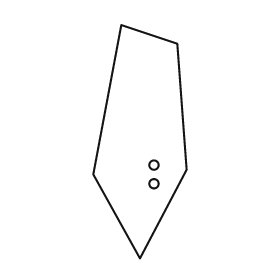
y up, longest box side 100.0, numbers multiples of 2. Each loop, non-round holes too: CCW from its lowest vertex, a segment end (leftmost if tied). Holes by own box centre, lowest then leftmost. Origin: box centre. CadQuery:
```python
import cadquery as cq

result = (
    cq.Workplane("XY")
    .moveTo(0.0, -50.0)
    .lineTo(20.0, -12.0)
    .lineTo(16.0, 42.0)
    .lineTo(-8.0, 50.0)
    .lineTo(-20.0, -14.0)
    .close()
    .moveTo(6.0, -18.0)
    .circle(2.0)
    .moveTo(6.0, -10.0)
    .circle(2.0)
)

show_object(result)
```